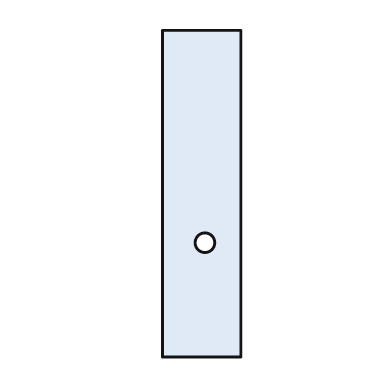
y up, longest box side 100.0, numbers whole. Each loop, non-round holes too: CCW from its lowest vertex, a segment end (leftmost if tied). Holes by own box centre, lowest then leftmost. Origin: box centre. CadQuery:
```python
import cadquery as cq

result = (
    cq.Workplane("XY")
    .moveTo(-12.0, -50.0)
    .lineTo(12.0, -50.0)
    .lineTo(12.0, 50.0)
    .lineTo(-12.0, 50.0)
    .close()
    .moveTo(1.0, -15.0)
    .circle(3.0)
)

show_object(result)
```